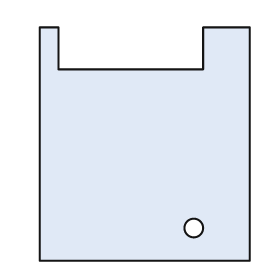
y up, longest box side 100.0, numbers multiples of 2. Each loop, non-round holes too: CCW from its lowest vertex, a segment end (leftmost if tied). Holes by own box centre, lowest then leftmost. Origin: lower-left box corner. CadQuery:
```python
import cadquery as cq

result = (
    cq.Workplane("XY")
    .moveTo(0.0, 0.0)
    .lineTo(90.0, 0.0)
    .lineTo(90.0, 100.0)
    .lineTo(70.0, 100.0)
    .lineTo(70.0, 82.0)
    .lineTo(8.0, 82.0)
    .lineTo(8.0, 100.0)
    .lineTo(0.0, 100.0)
    .close()
    .moveTo(66.0, 14.0)
    .circle(4.0)
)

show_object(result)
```